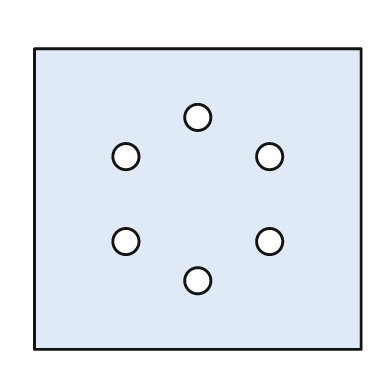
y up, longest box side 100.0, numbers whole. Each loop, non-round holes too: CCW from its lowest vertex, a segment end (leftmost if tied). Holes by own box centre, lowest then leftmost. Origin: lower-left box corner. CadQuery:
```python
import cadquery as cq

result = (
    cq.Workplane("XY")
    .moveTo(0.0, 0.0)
    .lineTo(100.0, 0.0)
    .lineTo(100.0, 92.0)
    .lineTo(0.0, 92.0)
    .close()
    .moveTo(50.0, 21.0)
    .circle(4.0)
    .moveTo(28.0, 33.0)
    .circle(4.0)
    .moveTo(72.0, 33.0)
    .circle(4.0)
    .moveTo(28.0, 59.0)
    .circle(4.0)
    .moveTo(72.0, 59.0)
    .circle(4.0)
    .moveTo(50.0, 71.0)
    .circle(4.0)
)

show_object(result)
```